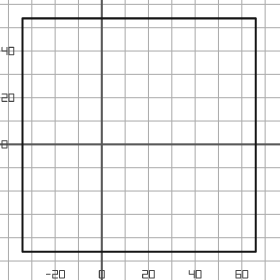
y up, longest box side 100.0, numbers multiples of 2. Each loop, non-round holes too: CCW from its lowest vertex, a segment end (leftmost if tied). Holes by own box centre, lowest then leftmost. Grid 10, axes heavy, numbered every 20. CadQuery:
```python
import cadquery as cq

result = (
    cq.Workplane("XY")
    .moveTo(-34.0, -46.0)
    .lineTo(66.0, -46.0)
    .lineTo(66.0, 54.0)
    .lineTo(-34.0, 54.0)
    .close()
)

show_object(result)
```